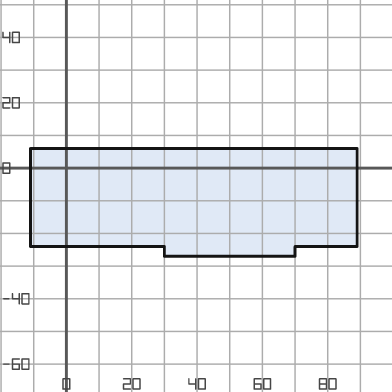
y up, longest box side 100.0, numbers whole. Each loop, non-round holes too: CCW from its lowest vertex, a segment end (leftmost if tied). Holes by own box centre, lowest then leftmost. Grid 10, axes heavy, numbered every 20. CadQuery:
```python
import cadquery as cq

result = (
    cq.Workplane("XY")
    .moveTo(30.0, -27.0)
    .lineTo(70.0, -27.0)
    .lineTo(70.0, -24.0)
    .lineTo(89.0, -24.0)
    .lineTo(89.0, 6.0)
    .lineTo(-11.0, 6.0)
    .lineTo(-11.0, -24.0)
    .lineTo(30.0, -24.0)
    .close()
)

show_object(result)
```